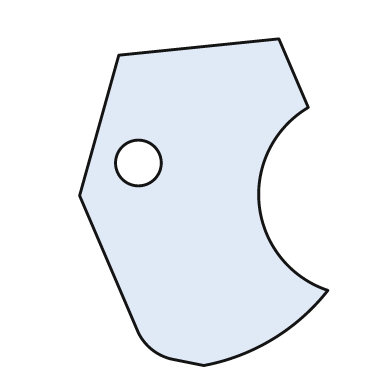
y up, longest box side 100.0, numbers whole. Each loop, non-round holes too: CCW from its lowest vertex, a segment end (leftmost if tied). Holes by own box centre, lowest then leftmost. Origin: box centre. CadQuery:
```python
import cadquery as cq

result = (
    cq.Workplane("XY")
    .moveTo(0.0, -50.0)
    .threePointArc((21.0, -42.0), (38.0, -27.0))
    .threePointArc((17.0, -1.0), (32.0, 29.0))
    .lineTo(23.0, 50.0)
    .lineTo(-26.0, 45.0)
    .lineTo(-38.0, 2.0)
    .lineTo(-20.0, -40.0)
    .threePointArc((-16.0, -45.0), (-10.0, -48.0))
    .close()
    .moveTo(-20.0, 12.0)
    .circle(7.0)
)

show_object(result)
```